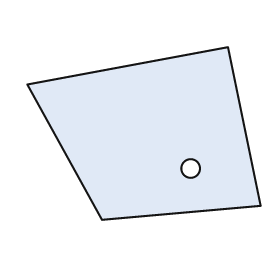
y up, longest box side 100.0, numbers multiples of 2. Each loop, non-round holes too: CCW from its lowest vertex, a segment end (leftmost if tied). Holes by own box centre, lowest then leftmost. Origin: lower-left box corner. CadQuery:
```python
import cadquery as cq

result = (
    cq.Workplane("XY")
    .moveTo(32.0, 0.0)
    .lineTo(100.0, 6.0)
    .lineTo(86.0, 74.0)
    .lineTo(0.0, 58.0)
    .close()
    .moveTo(70.0, 22.0)
    .circle(4.0)
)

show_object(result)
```